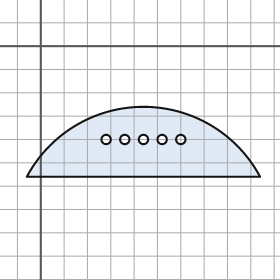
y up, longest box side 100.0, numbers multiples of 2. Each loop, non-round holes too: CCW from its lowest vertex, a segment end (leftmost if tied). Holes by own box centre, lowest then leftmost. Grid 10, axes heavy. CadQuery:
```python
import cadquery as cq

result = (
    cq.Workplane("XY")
    .moveTo(-6.0, -56.0)
    .lineTo(94.0, -56.0)
    .threePointArc((44.0, -26.0), (-6.0, -56.0))
    .close()
    .moveTo(28.0, -40.0)
    .circle(2.0)
    .moveTo(36.0, -40.0)
    .circle(2.0)
    .moveTo(44.0, -40.0)
    .circle(2.0)
    .moveTo(52.0, -40.0)
    .circle(2.0)
    .moveTo(60.0, -40.0)
    .circle(2.0)
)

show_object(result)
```